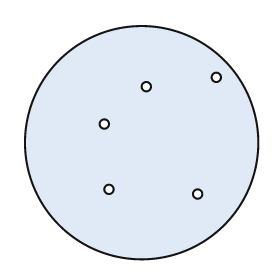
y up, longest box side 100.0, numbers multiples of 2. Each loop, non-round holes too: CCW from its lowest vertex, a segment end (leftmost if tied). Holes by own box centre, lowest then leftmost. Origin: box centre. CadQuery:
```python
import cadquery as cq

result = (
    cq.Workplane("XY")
    .moveTo(0.0, 0.0)
    .circle(50.0)
    .moveTo(24.0, -22.0)
    .circle(2.0)
    .moveTo(-14.0, -20.0)
    .circle(2.0)
    .moveTo(-16.0, 8.0)
    .circle(2.0)
    .moveTo(2.0, 24.0)
    .circle(2.0)
    .moveTo(32.0, 28.0)
    .circle(2.0)
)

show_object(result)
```